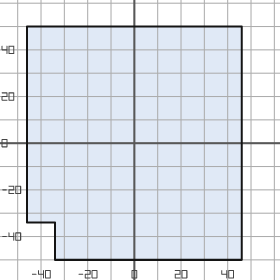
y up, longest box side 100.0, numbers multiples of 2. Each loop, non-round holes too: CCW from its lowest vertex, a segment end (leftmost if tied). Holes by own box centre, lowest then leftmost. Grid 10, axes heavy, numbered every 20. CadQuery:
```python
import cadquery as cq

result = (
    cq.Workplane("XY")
    .moveTo(-34.0, -50.0)
    .lineTo(46.0, -50.0)
    .lineTo(46.0, 50.0)
    .lineTo(-46.0, 50.0)
    .lineTo(-46.0, -34.0)
    .lineTo(-34.0, -34.0)
    .close()
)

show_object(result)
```